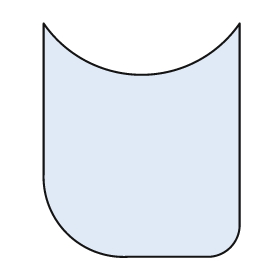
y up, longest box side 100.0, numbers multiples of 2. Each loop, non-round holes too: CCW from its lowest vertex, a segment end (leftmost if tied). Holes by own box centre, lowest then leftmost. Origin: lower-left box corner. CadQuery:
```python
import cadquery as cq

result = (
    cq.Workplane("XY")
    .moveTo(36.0, 0.0)
    .lineTo(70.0, 0.0)
    .threePointArc((80.0, 4.0), (84.0, 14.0))
    .lineTo(84.0, 100.0)
    .threePointArc((42.0, 78.0), (0.0, 100.0))
    .lineTo(0.0, 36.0)
    .threePointArc((10.0, 10.0), (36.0, 0.0))
    .close()
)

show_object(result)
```